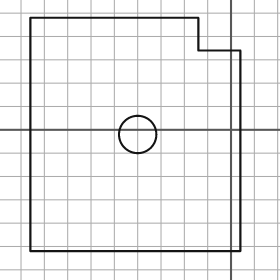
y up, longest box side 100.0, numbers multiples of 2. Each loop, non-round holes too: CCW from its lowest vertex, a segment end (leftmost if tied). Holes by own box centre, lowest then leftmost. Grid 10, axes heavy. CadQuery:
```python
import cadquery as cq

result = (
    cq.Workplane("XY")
    .moveTo(-86.0, -52.0)
    .lineTo(4.0, -52.0)
    .lineTo(4.0, 34.0)
    .lineTo(-14.0, 34.0)
    .lineTo(-14.0, 48.0)
    .lineTo(-86.0, 48.0)
    .close()
    .moveTo(-40.0, -2.0)
    .circle(8.0)
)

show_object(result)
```